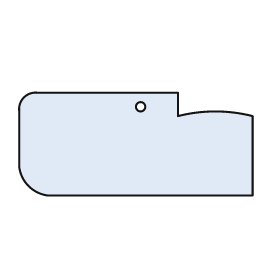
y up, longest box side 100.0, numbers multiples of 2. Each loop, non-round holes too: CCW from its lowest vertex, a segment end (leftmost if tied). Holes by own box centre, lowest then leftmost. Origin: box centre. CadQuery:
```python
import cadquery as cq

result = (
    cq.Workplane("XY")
    .moveTo(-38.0, -22.0)
    .lineTo(50.0, -22.0)
    .lineTo(50.0, 12.0)
    .threePointArc((34.0, 14.0), (18.0, 12.0))
    .lineTo(18.0, 22.0)
    .lineTo(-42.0, 22.0)
    .threePointArc((-48.0, 20.0), (-50.0, 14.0))
    .lineTo(-50.0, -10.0)
    .threePointArc((-46.0, -18.0), (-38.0, -22.0))
    .close()
    .moveTo(2.0, 16.0)
    .circle(2.0)
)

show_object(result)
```